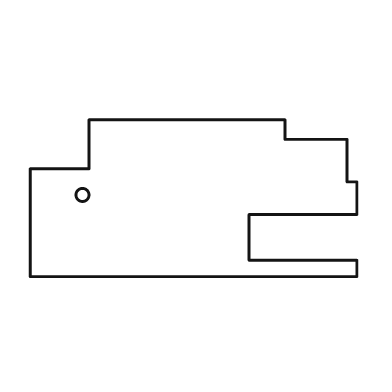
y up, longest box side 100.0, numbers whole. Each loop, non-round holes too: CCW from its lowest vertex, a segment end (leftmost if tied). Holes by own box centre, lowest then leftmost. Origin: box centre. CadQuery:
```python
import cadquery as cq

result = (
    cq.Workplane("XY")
    .moveTo(-50.0, -24.0)
    .lineTo(50.0, -24.0)
    .lineTo(50.0, -19.0)
    .lineTo(17.0, -19.0)
    .lineTo(17.0, -5.0)
    .lineTo(50.0, -5.0)
    .lineTo(50.0, 5.0)
    .lineTo(47.0, 5.0)
    .lineTo(47.0, 18.0)
    .lineTo(28.0, 18.0)
    .lineTo(28.0, 24.0)
    .lineTo(-32.0, 24.0)
    .lineTo(-32.0, 9.0)
    .lineTo(-50.0, 9.0)
    .close()
    .moveTo(-34.0, 1.0)
    .circle(2.0)
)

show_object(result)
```